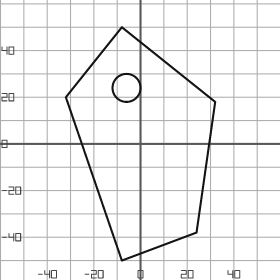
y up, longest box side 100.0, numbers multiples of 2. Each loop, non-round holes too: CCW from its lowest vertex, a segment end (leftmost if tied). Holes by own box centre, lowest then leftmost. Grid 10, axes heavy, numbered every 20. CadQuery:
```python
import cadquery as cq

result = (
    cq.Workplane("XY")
    .moveTo(-8.0, -50.0)
    .lineTo(24.0, -38.0)
    .lineTo(32.0, 18.0)
    .lineTo(-8.0, 50.0)
    .lineTo(-32.0, 20.0)
    .close()
    .moveTo(-6.0, 24.0)
    .circle(6.0)
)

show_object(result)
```